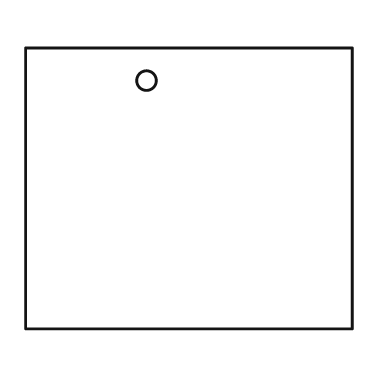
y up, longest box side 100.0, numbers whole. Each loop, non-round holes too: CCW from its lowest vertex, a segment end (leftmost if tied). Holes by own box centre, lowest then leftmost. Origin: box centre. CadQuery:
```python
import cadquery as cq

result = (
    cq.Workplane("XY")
    .moveTo(-50.0, -43.0)
    .lineTo(50.0, -43.0)
    .lineTo(50.0, 43.0)
    .lineTo(-50.0, 43.0)
    .close()
    .moveTo(-13.0, 33.0)
    .circle(3.0)
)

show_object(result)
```